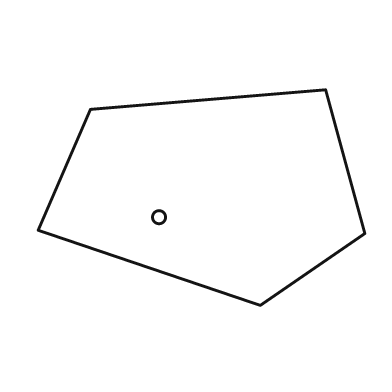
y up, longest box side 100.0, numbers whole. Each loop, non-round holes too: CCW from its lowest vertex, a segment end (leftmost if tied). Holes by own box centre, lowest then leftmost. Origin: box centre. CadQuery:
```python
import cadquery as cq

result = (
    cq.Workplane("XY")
    .moveTo(18.0, -33.0)
    .lineTo(50.0, -11.0)
    .lineTo(38.0, 33.0)
    .lineTo(-34.0, 27.0)
    .lineTo(-50.0, -10.0)
    .close()
    .moveTo(-13.0, -6.0)
    .circle(2.0)
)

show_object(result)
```